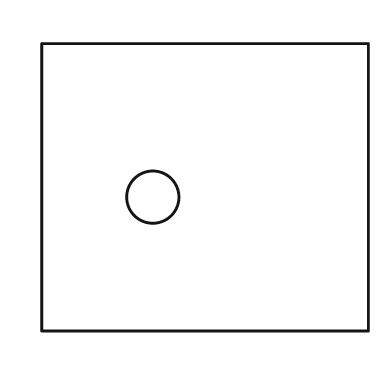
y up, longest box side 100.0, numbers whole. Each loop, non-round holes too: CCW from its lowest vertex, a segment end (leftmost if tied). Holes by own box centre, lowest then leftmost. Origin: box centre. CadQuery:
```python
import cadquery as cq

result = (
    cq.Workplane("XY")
    .moveTo(-50.0, -44.0)
    .lineTo(50.0, -44.0)
    .lineTo(50.0, 44.0)
    .lineTo(-50.0, 44.0)
    .close()
    .moveTo(-16.0, -3.0)
    .circle(8.0)
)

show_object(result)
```